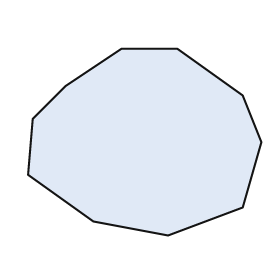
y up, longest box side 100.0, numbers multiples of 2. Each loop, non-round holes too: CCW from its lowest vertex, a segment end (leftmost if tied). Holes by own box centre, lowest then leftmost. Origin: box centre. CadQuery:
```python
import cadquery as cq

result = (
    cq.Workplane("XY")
    .moveTo(10.0, -40.0)
    .lineTo(42.0, -28.0)
    .lineTo(50.0, 0.0)
    .lineTo(42.0, 20.0)
    .lineTo(14.0, 40.0)
    .lineTo(-10.0, 40.0)
    .lineTo(-34.0, 24.0)
    .lineTo(-48.0, 10.0)
    .lineTo(-50.0, -14.0)
    .lineTo(-22.0, -34.0)
    .close()
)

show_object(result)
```